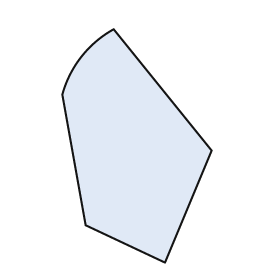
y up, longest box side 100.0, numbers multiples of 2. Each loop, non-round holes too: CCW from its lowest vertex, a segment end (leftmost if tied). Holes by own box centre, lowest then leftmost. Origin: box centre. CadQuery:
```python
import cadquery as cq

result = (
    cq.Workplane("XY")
    .moveTo(12.0, -50.0)
    .lineTo(32.0, -2.0)
    .lineTo(-10.0, 50.0)
    .threePointArc((-24.0, 38.0), (-32.0, 22.0))
    .lineTo(-22.0, -34.0)
    .close()
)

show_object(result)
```